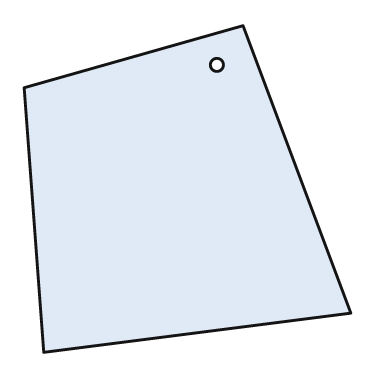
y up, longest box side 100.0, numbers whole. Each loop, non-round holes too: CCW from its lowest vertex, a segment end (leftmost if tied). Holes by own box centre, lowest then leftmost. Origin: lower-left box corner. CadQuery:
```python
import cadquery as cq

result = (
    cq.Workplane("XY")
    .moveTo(6.0, 0.0)
    .lineTo(100.0, 12.0)
    .lineTo(67.0, 100.0)
    .lineTo(0.0, 81.0)
    .close()
    .moveTo(59.0, 88.0)
    .circle(2.0)
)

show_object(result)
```